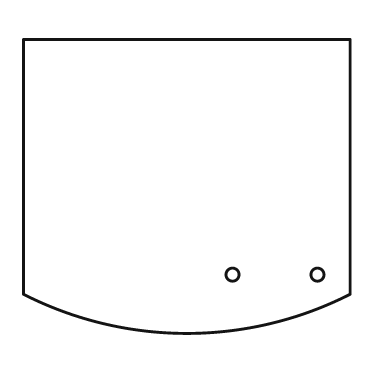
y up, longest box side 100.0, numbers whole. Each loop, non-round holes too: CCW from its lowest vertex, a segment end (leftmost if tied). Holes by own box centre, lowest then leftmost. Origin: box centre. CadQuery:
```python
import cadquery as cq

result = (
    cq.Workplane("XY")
    .moveTo(-50.0, -33.0)
    .threePointArc((0.0, -45.0), (50.0, -33.0))
    .lineTo(50.0, 45.0)
    .lineTo(-50.0, 45.0)
    .close()
    .moveTo(14.0, -27.0)
    .circle(2.0)
    .moveTo(40.0, -27.0)
    .circle(2.0)
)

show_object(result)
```